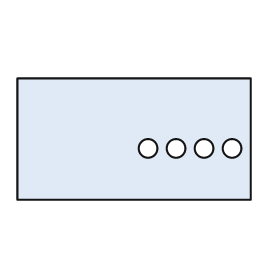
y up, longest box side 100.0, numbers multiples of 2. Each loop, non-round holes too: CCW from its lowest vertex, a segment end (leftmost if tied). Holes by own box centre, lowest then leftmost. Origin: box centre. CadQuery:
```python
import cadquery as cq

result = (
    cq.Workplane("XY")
    .moveTo(-50.0, -26.0)
    .lineTo(50.0, -26.0)
    .lineTo(50.0, 26.0)
    .lineTo(-50.0, 26.0)
    .close()
    .moveTo(6.0, -4.0)
    .circle(4.0)
    .moveTo(18.0, -4.0)
    .circle(4.0)
    .moveTo(30.0, -4.0)
    .circle(4.0)
    .moveTo(42.0, -4.0)
    .circle(4.0)
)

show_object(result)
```